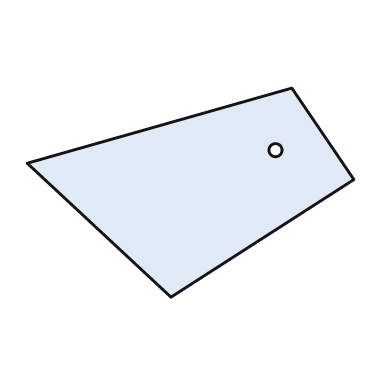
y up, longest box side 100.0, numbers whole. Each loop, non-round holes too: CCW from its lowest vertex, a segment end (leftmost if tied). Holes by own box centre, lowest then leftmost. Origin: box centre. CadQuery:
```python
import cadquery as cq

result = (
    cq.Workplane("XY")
    .moveTo(-6.0, -32.0)
    .lineTo(50.0, 4.0)
    .lineTo(31.0, 32.0)
    .lineTo(-50.0, 9.0)
    .close()
    .moveTo(26.0, 13.0)
    .circle(2.0)
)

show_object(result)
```